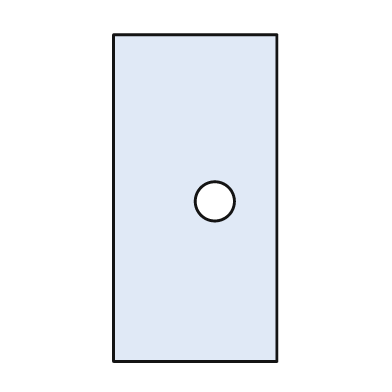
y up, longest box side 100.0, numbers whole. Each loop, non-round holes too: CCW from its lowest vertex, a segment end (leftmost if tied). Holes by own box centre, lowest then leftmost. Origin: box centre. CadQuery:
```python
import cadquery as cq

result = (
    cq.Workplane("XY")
    .moveTo(-25.0, -50.0)
    .lineTo(25.0, -50.0)
    .lineTo(25.0, 50.0)
    .lineTo(-25.0, 50.0)
    .close()
    .moveTo(6.0, -1.0)
    .circle(6.0)
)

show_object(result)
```